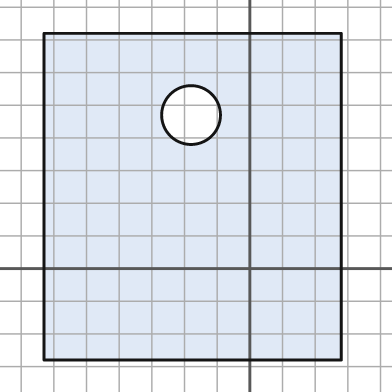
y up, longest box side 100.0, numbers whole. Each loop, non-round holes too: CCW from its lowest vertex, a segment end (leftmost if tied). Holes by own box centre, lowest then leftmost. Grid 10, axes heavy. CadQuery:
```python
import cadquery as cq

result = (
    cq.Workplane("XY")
    .moveTo(-63.0, -28.0)
    .lineTo(28.0, -28.0)
    .lineTo(28.0, 72.0)
    .lineTo(-63.0, 72.0)
    .close()
    .moveTo(-18.0, 47.0)
    .circle(9.0)
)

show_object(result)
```